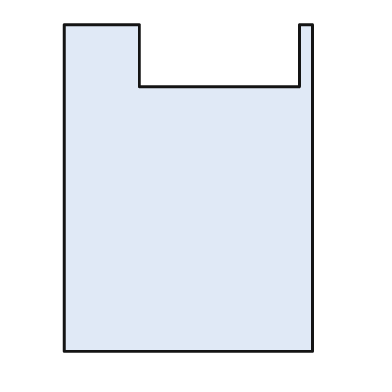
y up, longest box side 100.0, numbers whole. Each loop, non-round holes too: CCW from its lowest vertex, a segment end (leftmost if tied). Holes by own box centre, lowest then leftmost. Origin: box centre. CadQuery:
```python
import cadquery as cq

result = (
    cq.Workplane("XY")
    .moveTo(-38.0, -50.0)
    .lineTo(38.0, -50.0)
    .lineTo(38.0, 50.0)
    .lineTo(34.0, 50.0)
    .lineTo(34.0, 31.0)
    .lineTo(-15.0, 31.0)
    .lineTo(-15.0, 50.0)
    .lineTo(-38.0, 50.0)
    .close()
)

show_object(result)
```